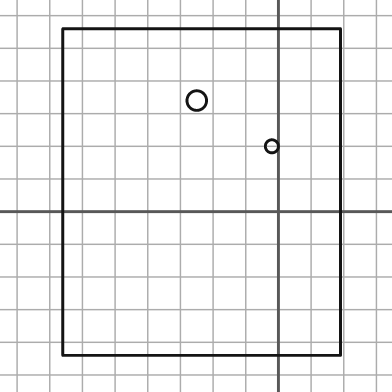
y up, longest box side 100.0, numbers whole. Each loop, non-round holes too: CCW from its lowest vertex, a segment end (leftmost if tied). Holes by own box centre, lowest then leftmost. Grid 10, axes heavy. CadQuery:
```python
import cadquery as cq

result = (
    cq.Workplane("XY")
    .moveTo(-66.0, -44.0)
    .lineTo(19.0, -44.0)
    .lineTo(19.0, 56.0)
    .lineTo(-66.0, 56.0)
    .close()
    .moveTo(-2.0, 20.0)
    .circle(2.0)
    .moveTo(-25.0, 34.0)
    .circle(3.0)
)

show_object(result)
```